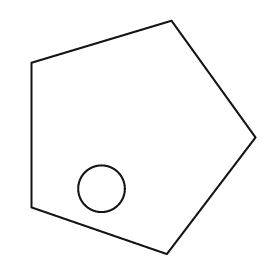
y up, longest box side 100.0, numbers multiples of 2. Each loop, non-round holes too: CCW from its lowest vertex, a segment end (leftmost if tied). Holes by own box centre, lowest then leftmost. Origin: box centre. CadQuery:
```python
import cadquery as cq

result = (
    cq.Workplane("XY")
    .moveTo(10.0, -50.0)
    .lineTo(48.0, 0.0)
    .lineTo(12.0, 50.0)
    .lineTo(-48.0, 32.0)
    .lineTo(-48.0, -30.0)
    .close()
    .moveTo(-18.0, -22.0)
    .circle(10.0)
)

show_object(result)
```